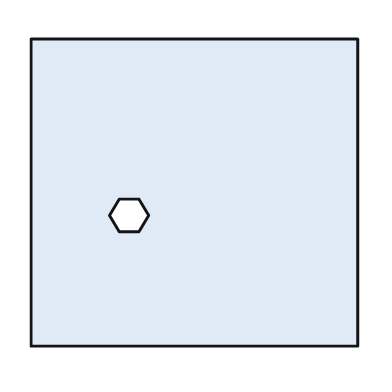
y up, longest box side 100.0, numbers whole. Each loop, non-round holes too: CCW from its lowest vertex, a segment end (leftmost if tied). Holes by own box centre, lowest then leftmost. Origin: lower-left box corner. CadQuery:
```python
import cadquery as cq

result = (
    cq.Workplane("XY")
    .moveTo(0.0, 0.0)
    .lineTo(100.0, 0.0)
    .lineTo(100.0, 94.0)
    .lineTo(0.0, 94.0)
    .close()
    .moveTo(27.0, 35.0)
    .lineTo(33.0, 35.0)
    .lineTo(36.0, 40.0)
    .lineTo(33.0, 45.0)
    .lineTo(27.0, 45.0)
    .lineTo(24.0, 40.0)
    .close()
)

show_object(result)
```